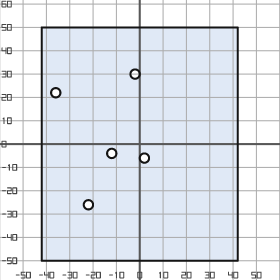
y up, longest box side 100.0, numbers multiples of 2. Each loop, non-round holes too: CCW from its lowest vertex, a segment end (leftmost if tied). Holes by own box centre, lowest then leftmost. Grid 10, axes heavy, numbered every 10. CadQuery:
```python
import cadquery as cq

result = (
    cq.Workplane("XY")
    .moveTo(-42.0, -50.0)
    .lineTo(42.0, -50.0)
    .lineTo(42.0, 50.0)
    .lineTo(-42.0, 50.0)
    .close()
    .moveTo(-22.0, -26.0)
    .circle(2.0)
    .moveTo(2.0, -6.0)
    .circle(2.0)
    .moveTo(-12.0, -4.0)
    .circle(2.0)
    .moveTo(-36.0, 22.0)
    .circle(2.0)
    .moveTo(-2.0, 30.0)
    .circle(2.0)
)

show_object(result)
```